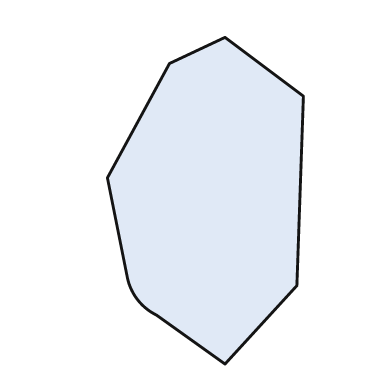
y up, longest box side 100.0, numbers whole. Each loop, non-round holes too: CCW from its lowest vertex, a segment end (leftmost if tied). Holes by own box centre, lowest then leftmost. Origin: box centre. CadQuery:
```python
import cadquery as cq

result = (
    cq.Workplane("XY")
    .moveTo(6.0, -50.0)
    .lineTo(28.0, -26.0)
    .lineTo(30.0, 32.0)
    .lineTo(6.0, 50.0)
    .lineTo(-11.0, 42.0)
    .lineTo(-30.0, 7.0)
    .lineTo(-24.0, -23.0)
    .threePointArc((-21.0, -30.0), (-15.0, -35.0))
    .close()
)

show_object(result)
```